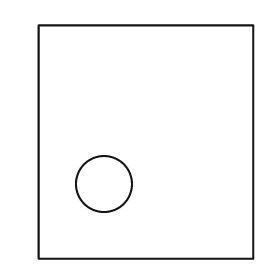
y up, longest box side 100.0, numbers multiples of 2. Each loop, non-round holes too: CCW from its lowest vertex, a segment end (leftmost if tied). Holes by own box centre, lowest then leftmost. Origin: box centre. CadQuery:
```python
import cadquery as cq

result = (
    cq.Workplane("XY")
    .moveTo(-46.0, -50.0)
    .lineTo(46.0, -50.0)
    .lineTo(46.0, 50.0)
    .lineTo(-46.0, 50.0)
    .close()
    .moveTo(-18.0, -18.0)
    .circle(12.0)
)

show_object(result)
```